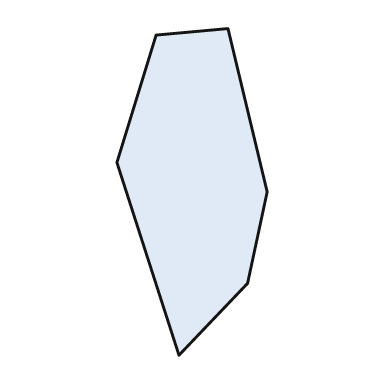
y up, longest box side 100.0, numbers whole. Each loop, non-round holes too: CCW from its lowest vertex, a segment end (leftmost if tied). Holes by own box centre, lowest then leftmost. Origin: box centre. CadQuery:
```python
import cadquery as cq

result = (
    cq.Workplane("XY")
    .moveTo(-4.0, -50.0)
    .lineTo(17.0, -28.0)
    .lineTo(23.0, 0.0)
    .lineTo(11.0, 50.0)
    .lineTo(-11.0, 48.0)
    .lineTo(-23.0, 9.0)
    .close()
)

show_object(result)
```